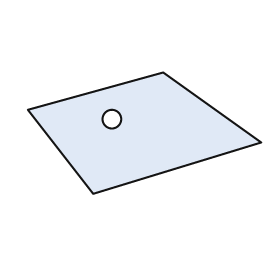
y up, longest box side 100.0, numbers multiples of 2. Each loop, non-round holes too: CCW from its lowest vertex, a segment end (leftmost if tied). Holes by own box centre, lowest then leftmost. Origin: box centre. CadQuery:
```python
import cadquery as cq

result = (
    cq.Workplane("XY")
    .moveTo(-22.0, -26.0)
    .lineTo(50.0, -4.0)
    .lineTo(8.0, 26.0)
    .lineTo(-50.0, 10.0)
    .close()
    .moveTo(-14.0, 6.0)
    .circle(4.0)
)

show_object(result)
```